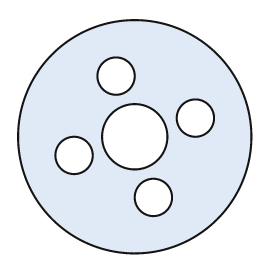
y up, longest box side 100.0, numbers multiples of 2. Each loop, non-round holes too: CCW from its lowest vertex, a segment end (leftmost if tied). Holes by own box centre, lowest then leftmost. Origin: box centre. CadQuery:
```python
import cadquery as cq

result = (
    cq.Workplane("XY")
    .moveTo(0.0, 0.0)
    .circle(50.0)
    .moveTo(8.0, -26.0)
    .circle(8.0)
    .moveTo(-26.0, -8.0)
    .circle(8.0)
    .moveTo(0.0, 0.0)
    .circle(14.0)
    .moveTo(26.0, 8.0)
    .circle(8.0)
    .moveTo(-8.0, 26.0)
    .circle(8.0)
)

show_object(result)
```